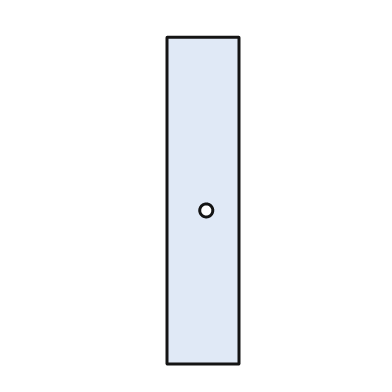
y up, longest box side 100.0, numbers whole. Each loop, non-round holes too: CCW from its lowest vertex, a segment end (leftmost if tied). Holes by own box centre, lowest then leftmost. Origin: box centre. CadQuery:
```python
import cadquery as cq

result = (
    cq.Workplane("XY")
    .moveTo(-11.0, -50.0)
    .lineTo(11.0, -50.0)
    .lineTo(11.0, 50.0)
    .lineTo(-11.0, 50.0)
    .close()
    .moveTo(1.0, -3.0)
    .circle(2.0)
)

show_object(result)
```